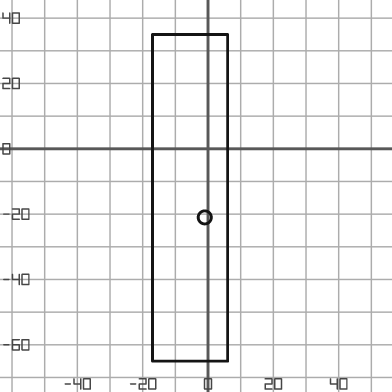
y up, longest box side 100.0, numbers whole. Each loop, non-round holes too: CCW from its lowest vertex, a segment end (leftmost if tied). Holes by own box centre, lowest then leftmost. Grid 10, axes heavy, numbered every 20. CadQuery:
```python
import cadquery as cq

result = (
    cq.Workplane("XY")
    .moveTo(-17.0, -65.0)
    .lineTo(6.0, -65.0)
    .lineTo(6.0, 35.0)
    .lineTo(-17.0, 35.0)
    .close()
    .moveTo(-1.0, -21.0)
    .circle(2.0)
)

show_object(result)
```